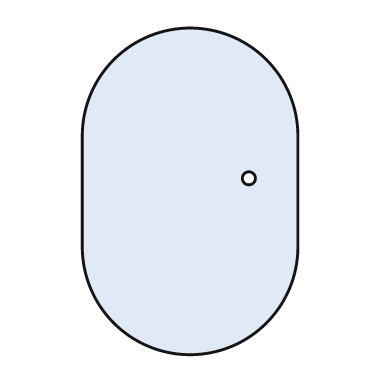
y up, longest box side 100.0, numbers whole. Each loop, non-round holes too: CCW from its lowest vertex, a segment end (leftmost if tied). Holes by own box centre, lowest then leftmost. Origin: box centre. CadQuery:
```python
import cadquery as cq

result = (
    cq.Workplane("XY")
    .moveTo(-33.0, -17.0)
    .threePointArc((0.0, -50.0), (33.0, -17.0))
    .lineTo(33.0, 17.0)
    .threePointArc((0.0, 50.0), (-33.0, 17.0))
    .close()
    .moveTo(18.0, 4.0)
    .circle(2.0)
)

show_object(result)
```